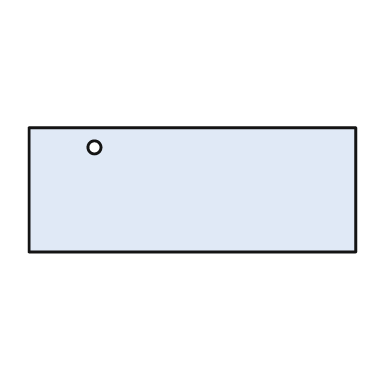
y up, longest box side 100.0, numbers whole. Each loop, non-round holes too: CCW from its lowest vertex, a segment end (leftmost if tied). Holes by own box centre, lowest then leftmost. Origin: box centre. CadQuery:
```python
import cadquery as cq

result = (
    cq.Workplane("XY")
    .moveTo(-50.0, -19.0)
    .lineTo(50.0, -19.0)
    .lineTo(50.0, 19.0)
    .lineTo(-50.0, 19.0)
    .close()
    .moveTo(-30.0, 13.0)
    .circle(2.0)
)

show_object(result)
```